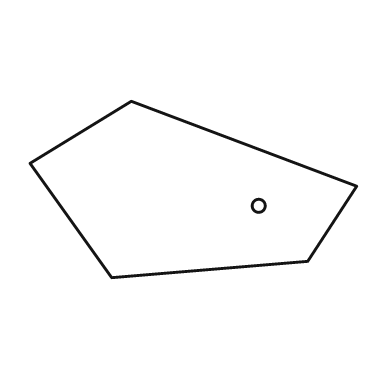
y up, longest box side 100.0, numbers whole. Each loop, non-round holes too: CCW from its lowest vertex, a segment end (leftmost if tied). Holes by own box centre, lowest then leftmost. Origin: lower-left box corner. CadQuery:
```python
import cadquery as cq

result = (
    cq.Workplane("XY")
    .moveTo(25.0, 0.0)
    .lineTo(85.0, 5.0)
    .lineTo(100.0, 28.0)
    .lineTo(31.0, 54.0)
    .lineTo(0.0, 35.0)
    .close()
    .moveTo(70.0, 22.0)
    .circle(2.0)
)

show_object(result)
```